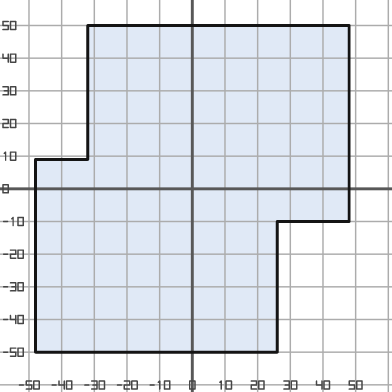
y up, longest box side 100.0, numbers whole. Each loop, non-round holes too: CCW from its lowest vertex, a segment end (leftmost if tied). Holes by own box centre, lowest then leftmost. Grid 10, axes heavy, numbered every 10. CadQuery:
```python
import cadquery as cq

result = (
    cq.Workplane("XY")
    .moveTo(-48.0, -50.0)
    .lineTo(26.0, -50.0)
    .lineTo(26.0, -10.0)
    .lineTo(48.0, -10.0)
    .lineTo(48.0, 50.0)
    .lineTo(-32.0, 50.0)
    .lineTo(-32.0, 9.0)
    .lineTo(-48.0, 9.0)
    .close()
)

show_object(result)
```